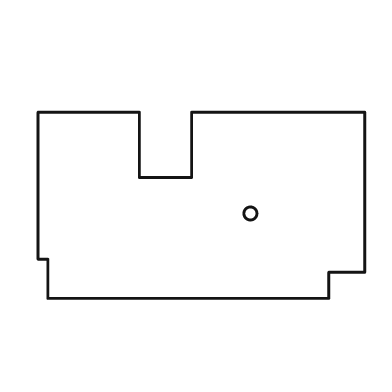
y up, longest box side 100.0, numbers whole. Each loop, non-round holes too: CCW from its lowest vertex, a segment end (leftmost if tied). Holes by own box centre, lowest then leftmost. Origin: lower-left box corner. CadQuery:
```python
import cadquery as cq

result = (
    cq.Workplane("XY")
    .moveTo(3.0, 0.0)
    .lineTo(89.0, 0.0)
    .lineTo(89.0, 8.0)
    .lineTo(100.0, 8.0)
    .lineTo(100.0, 57.0)
    .lineTo(47.0, 57.0)
    .lineTo(47.0, 37.0)
    .lineTo(31.0, 37.0)
    .lineTo(31.0, 57.0)
    .lineTo(0.0, 57.0)
    .lineTo(0.0, 12.0)
    .lineTo(3.0, 12.0)
    .close()
    .moveTo(65.0, 26.0)
    .circle(2.0)
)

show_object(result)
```